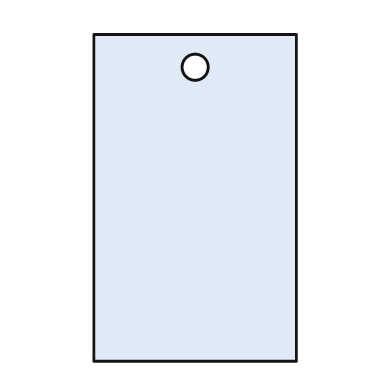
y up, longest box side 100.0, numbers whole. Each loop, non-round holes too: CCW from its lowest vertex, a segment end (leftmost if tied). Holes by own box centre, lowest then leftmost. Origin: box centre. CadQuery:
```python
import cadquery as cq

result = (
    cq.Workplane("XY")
    .moveTo(-31.0, -50.0)
    .lineTo(31.0, -50.0)
    .lineTo(31.0, 50.0)
    .lineTo(-31.0, 50.0)
    .close()
    .moveTo(0.0, 40.0)
    .circle(4.0)
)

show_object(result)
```